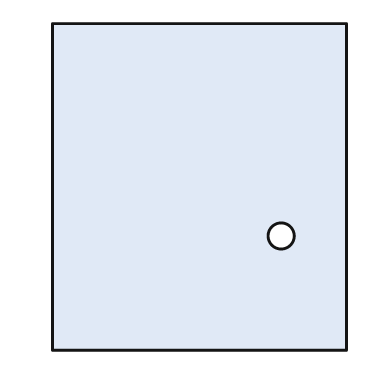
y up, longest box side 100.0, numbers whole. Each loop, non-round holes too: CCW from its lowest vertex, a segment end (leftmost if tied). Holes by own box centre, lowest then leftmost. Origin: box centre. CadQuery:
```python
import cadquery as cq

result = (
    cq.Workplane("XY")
    .moveTo(-45.0, -50.0)
    .lineTo(45.0, -50.0)
    .lineTo(45.0, 50.0)
    .lineTo(-45.0, 50.0)
    .close()
    .moveTo(25.0, -15.0)
    .circle(4.0)
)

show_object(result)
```